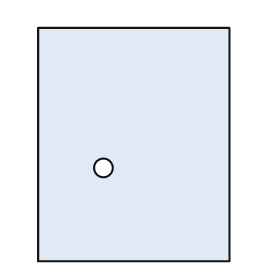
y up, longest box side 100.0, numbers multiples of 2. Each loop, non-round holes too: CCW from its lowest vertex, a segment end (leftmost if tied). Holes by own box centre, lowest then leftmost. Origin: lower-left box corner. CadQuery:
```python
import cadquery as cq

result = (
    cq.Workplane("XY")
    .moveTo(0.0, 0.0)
    .lineTo(82.0, 0.0)
    .lineTo(82.0, 100.0)
    .lineTo(0.0, 100.0)
    .close()
    .moveTo(28.0, 40.0)
    .circle(4.0)
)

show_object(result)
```